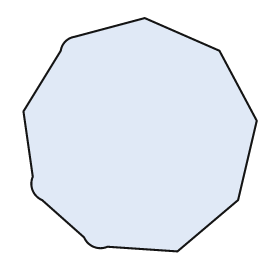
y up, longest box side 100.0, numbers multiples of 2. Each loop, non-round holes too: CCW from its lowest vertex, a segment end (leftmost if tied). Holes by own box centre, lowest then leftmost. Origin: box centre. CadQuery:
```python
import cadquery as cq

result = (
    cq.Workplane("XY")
    .moveTo(16.0, -50.0)
    .lineTo(42.0, -28.0)
    .lineTo(50.0, 6.0)
    .lineTo(34.0, 36.0)
    .lineTo(2.0, 50.0)
    .lineTo(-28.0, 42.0)
    .threePointArc((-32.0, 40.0), (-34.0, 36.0))
    .lineTo(-50.0, 10.0)
    .lineTo(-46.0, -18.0)
    .threePointArc((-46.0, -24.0), (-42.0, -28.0))
    .lineTo(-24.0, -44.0)
    .threePointArc((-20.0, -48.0), (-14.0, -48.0))
    .close()
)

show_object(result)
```